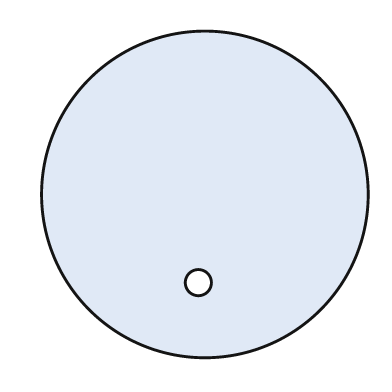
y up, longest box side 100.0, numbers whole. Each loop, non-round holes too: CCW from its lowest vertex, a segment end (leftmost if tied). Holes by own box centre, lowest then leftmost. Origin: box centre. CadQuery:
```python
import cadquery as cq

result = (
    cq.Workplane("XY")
    .moveTo(0.0, 0.0)
    .circle(50.0)
    .moveTo(-2.0, -27.0)
    .circle(4.0)
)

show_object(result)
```